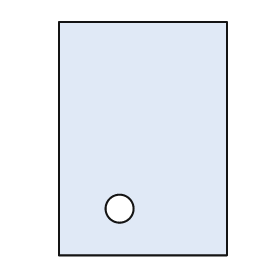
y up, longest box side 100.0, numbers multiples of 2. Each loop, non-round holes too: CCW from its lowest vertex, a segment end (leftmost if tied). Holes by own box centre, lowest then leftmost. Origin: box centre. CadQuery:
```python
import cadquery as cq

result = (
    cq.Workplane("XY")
    .moveTo(-36.0, -50.0)
    .lineTo(36.0, -50.0)
    .lineTo(36.0, 50.0)
    .lineTo(-36.0, 50.0)
    .close()
    .moveTo(-10.0, -30.0)
    .circle(6.0)
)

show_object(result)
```